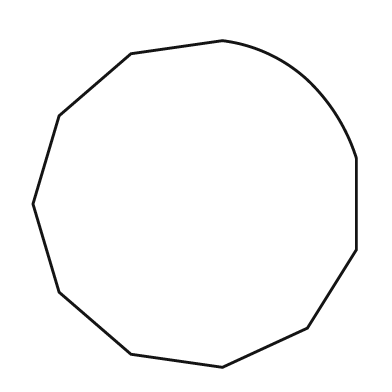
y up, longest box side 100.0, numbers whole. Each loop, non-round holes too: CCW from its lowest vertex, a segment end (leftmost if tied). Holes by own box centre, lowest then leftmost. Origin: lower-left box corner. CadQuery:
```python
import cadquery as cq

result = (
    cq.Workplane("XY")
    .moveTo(58.0, 0.0)
    .lineTo(84.0, 12.0)
    .lineTo(99.0, 36.0)
    .lineTo(99.0, 64.0)
    .threePointArc((93.0, 77.0), (84.0, 88.0))
    .threePointArc((72.0, 96.0), (58.0, 100.0))
    .lineTo(30.0, 96.0)
    .lineTo(8.0, 77.0)
    .lineTo(0.0, 50.0)
    .lineTo(8.0, 23.0)
    .lineTo(30.0, 4.0)
    .close()
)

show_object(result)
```